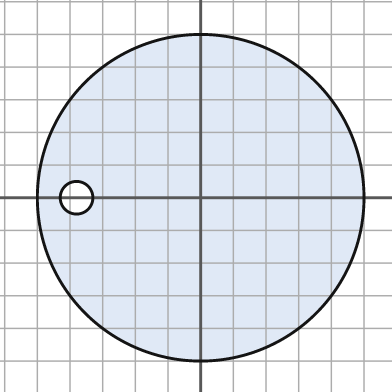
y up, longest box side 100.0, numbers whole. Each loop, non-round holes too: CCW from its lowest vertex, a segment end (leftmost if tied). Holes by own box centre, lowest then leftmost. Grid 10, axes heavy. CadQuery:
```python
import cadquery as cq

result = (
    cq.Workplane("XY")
    .moveTo(0.0, 0.0)
    .circle(50.0)
    .moveTo(-38.0, 0.0)
    .circle(5.0)
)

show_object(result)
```